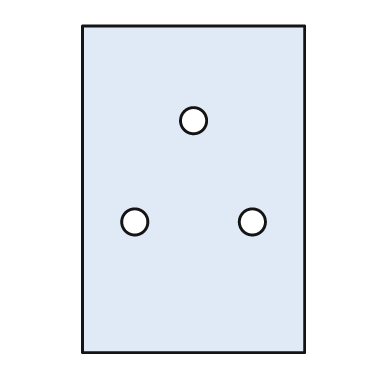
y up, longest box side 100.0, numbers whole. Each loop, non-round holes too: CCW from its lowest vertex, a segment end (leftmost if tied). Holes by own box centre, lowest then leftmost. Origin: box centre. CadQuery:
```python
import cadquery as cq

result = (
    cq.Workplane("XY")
    .moveTo(-34.0, -50.0)
    .lineTo(34.0, -50.0)
    .lineTo(34.0, 50.0)
    .lineTo(-34.0, 50.0)
    .close()
    .moveTo(-18.0, -10.0)
    .circle(4.0)
    .moveTo(18.0, -10.0)
    .circle(4.0)
    .moveTo(0.0, 21.0)
    .circle(4.0)
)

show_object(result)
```